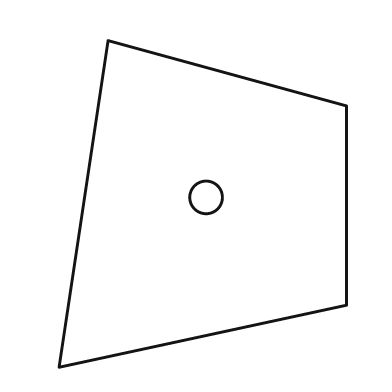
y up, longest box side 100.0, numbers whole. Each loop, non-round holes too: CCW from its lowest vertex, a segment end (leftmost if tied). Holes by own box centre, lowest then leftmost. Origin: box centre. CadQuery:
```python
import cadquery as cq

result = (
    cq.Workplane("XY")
    .moveTo(-44.0, -50.0)
    .lineTo(44.0, -31.0)
    .lineTo(44.0, 30.0)
    .lineTo(-29.0, 50.0)
    .close()
    .moveTo(1.0, 2.0)
    .circle(5.0)
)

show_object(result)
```